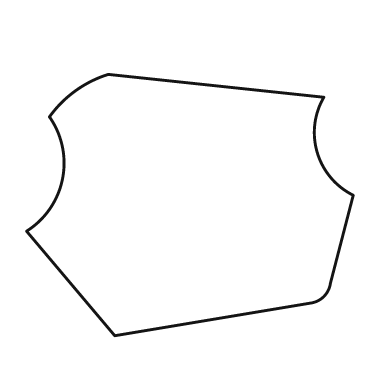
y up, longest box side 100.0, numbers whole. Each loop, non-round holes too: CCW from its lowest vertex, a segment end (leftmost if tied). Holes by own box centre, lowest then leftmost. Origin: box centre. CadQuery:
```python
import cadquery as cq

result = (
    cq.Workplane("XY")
    .moveTo(-23.0, -40.0)
    .lineTo(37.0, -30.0)
    .threePointArc((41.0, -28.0), (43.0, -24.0))
    .lineTo(50.0, 3.0)
    .threePointArc((39.0, 16.0), (41.0, 33.0))
    .lineTo(-25.0, 40.0)
    .threePointArc((-35.0, 35.0), (-43.0, 27.0))
    .threePointArc((-39.0, 8.0), (-50.0, -8.0))
    .close()
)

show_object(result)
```